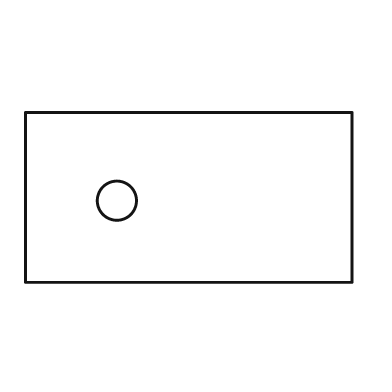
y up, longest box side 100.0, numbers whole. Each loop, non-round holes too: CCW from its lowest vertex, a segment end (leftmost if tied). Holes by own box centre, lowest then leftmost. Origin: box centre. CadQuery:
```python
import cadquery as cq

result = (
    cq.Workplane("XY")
    .moveTo(-50.0, -26.0)
    .lineTo(50.0, -26.0)
    .lineTo(50.0, 26.0)
    .lineTo(-50.0, 26.0)
    .close()
    .moveTo(-22.0, -1.0)
    .circle(6.0)
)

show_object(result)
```